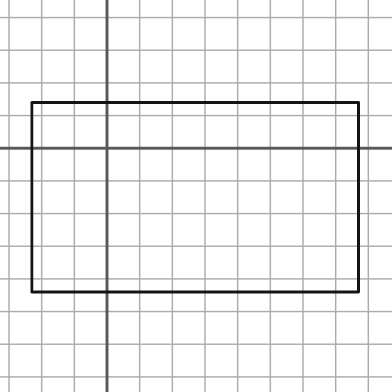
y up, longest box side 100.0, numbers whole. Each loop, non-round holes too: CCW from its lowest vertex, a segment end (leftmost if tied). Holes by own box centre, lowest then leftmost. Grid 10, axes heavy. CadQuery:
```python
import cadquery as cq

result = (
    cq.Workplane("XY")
    .moveTo(-23.0, -44.0)
    .lineTo(77.0, -44.0)
    .lineTo(77.0, 14.0)
    .lineTo(-23.0, 14.0)
    .close()
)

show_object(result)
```